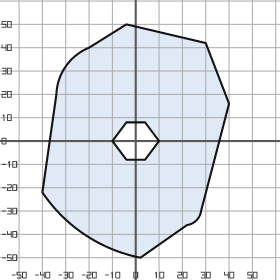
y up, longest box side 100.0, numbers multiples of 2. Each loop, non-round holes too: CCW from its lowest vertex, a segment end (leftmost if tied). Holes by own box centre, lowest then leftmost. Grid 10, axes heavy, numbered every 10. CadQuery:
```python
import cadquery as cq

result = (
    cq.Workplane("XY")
    .moveTo(2.0, -50.0)
    .lineTo(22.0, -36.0)
    .threePointArc((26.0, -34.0), (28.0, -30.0))
    .lineTo(40.0, 16.0)
    .lineTo(30.0, 42.0)
    .lineTo(-4.0, 50.0)
    .lineTo(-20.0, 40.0)
    .threePointArc((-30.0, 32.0), (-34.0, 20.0))
    .lineTo(-40.0, -22.0)
    .threePointArc((-22.0, -40.0), (2.0, -50.0))
    .close()
    .moveTo(-4.0, -8.0)
    .lineTo(4.0, -8.0)
    .lineTo(10.0, 0.0)
    .lineTo(4.0, 8.0)
    .lineTo(-4.0, 8.0)
    .lineTo(-10.0, 0.0)
    .close()
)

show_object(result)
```